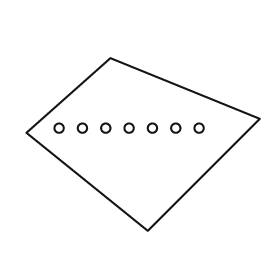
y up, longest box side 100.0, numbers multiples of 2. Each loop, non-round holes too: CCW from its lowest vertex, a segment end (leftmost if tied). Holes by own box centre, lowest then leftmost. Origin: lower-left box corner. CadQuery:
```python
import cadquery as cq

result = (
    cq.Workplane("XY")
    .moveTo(52.0, 0.0)
    .lineTo(100.0, 48.0)
    .lineTo(36.0, 74.0)
    .lineTo(0.0, 42.0)
    .close()
    .moveTo(14.0, 44.0)
    .circle(2.0)
    .moveTo(24.0, 44.0)
    .circle(2.0)
    .moveTo(34.0, 44.0)
    .circle(2.0)
    .moveTo(44.0, 44.0)
    .circle(2.0)
    .moveTo(54.0, 44.0)
    .circle(2.0)
    .moveTo(64.0, 44.0)
    .circle(2.0)
    .moveTo(74.0, 44.0)
    .circle(2.0)
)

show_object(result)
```